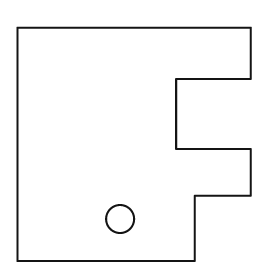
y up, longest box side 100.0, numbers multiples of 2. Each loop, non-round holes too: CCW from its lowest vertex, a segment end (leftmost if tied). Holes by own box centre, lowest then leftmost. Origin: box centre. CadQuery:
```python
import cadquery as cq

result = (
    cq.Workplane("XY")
    .moveTo(-50.0, -50.0)
    .lineTo(26.0, -50.0)
    .lineTo(26.0, -22.0)
    .lineTo(50.0, -22.0)
    .lineTo(50.0, -2.0)
    .lineTo(18.0, -2.0)
    .lineTo(18.0, 28.0)
    .lineTo(50.0, 28.0)
    .lineTo(50.0, 50.0)
    .lineTo(-50.0, 50.0)
    .close()
    .moveTo(-6.0, -32.0)
    .circle(6.0)
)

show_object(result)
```